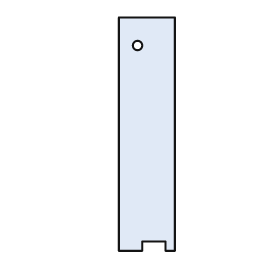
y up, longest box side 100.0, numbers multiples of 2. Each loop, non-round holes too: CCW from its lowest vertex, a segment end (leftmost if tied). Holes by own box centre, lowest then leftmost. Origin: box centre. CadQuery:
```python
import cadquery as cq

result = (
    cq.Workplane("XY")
    .moveTo(-12.0, -50.0)
    .lineTo(-2.0, -50.0)
    .lineTo(-2.0, -46.0)
    .lineTo(8.0, -46.0)
    .lineTo(8.0, -50.0)
    .lineTo(12.0, -50.0)
    .lineTo(12.0, 50.0)
    .lineTo(-12.0, 50.0)
    .close()
    .moveTo(-4.0, 38.0)
    .circle(2.0)
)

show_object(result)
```